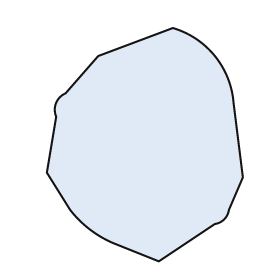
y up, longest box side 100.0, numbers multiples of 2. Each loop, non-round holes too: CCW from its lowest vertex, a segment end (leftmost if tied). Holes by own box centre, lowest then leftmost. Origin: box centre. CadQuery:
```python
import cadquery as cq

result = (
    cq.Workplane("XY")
    .moveTo(6.0, -50.0)
    .lineTo(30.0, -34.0)
    .threePointArc((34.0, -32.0), (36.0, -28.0))
    .lineTo(42.0, -14.0)
    .lineTo(38.0, 18.0)
    .threePointArc((30.0, 38.0), (12.0, 50.0))
    .lineTo(-20.0, 38.0)
    .lineTo(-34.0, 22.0)
    .threePointArc((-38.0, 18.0), (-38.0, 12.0))
    .lineTo(-42.0, -12.0)
    .lineTo(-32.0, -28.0)
    .threePointArc((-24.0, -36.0), (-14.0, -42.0))
    .close()
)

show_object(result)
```